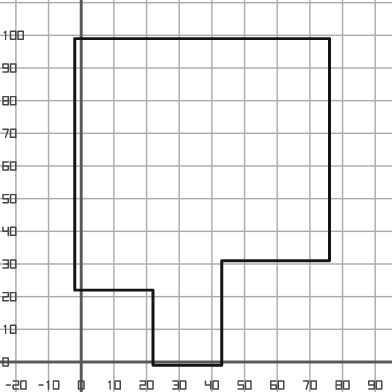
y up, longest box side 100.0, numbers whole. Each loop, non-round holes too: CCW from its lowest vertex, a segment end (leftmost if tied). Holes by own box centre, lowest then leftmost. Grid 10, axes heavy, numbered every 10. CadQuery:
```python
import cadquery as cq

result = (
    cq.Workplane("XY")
    .moveTo(22.0, -1.0)
    .lineTo(43.0, -1.0)
    .lineTo(43.0, 31.0)
    .lineTo(76.0, 31.0)
    .lineTo(76.0, 99.0)
    .lineTo(-2.0, 99.0)
    .lineTo(-2.0, 22.0)
    .lineTo(22.0, 22.0)
    .close()
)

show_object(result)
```